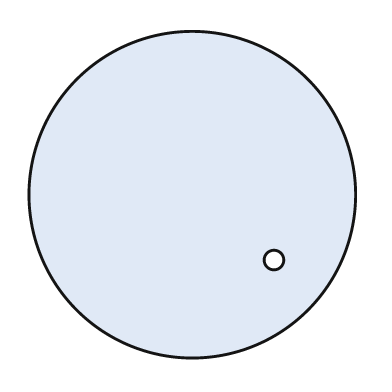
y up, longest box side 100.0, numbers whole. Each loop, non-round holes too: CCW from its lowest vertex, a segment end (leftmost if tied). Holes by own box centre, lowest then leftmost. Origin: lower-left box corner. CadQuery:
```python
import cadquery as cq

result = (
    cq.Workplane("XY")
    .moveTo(50.0, 50.0)
    .circle(50.0)
    .moveTo(75.0, 30.0)
    .circle(3.0)
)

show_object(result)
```